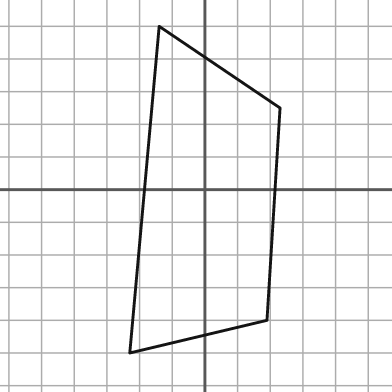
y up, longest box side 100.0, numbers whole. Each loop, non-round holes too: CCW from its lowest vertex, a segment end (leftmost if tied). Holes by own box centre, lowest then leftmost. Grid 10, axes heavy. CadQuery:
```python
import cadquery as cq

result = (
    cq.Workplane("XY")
    .moveTo(-23.0, -50.0)
    .lineTo(19.0, -40.0)
    .lineTo(23.0, 25.0)
    .lineTo(-14.0, 50.0)
    .close()
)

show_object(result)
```